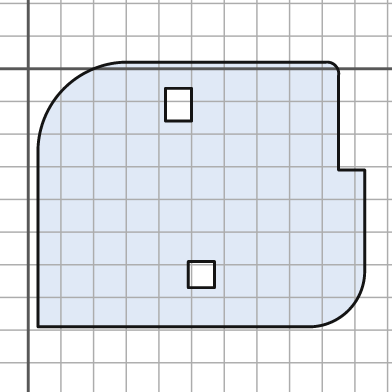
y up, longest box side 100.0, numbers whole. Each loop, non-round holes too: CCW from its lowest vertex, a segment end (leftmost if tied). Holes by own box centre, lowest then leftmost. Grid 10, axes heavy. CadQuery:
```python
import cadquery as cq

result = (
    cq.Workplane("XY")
    .moveTo(3.0, -79.0)
    .lineTo(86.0, -79.0)
    .threePointArc((98.0, -74.0), (103.0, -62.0))
    .lineTo(103.0, -31.0)
    .lineTo(95.0, -31.0)
    .lineTo(95.0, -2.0)
    .threePointArc((94.0, 1.0), (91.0, 2.0))
    .lineTo(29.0, 2.0)
    .threePointArc((11.0, -6.0), (3.0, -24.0))
    .close()
    .moveTo(49.0, -67.0)
    .lineTo(57.0, -67.0)
    .lineTo(57.0, -59.0)
    .lineTo(49.0, -59.0)
    .close()
    .moveTo(42.0, -16.0)
    .lineTo(50.0, -16.0)
    .lineTo(50.0, -6.0)
    .lineTo(42.0, -6.0)
    .close()
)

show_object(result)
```